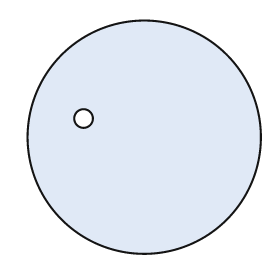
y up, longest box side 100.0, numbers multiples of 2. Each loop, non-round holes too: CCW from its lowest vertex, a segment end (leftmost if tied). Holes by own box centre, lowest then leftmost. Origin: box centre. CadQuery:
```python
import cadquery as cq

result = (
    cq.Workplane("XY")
    .moveTo(0.0, 0.0)
    .circle(50.0)
    .moveTo(-26.0, 8.0)
    .circle(4.0)
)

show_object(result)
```